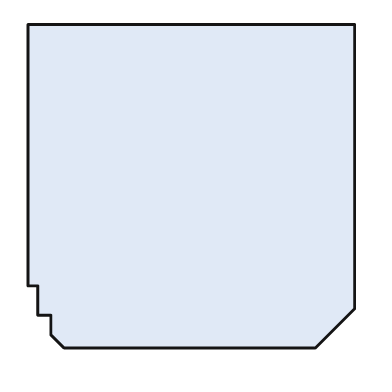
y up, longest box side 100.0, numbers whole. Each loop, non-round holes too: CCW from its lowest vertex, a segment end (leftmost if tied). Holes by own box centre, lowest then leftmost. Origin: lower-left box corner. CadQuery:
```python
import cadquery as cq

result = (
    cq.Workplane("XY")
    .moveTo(11.0, 0.0)
    .lineTo(88.0, 0.0)
    .lineTo(100.0, 12.0)
    .lineTo(100.0, 99.0)
    .lineTo(0.0, 99.0)
    .lineTo(0.0, 19.0)
    .lineTo(3.0, 19.0)
    .lineTo(3.0, 10.0)
    .lineTo(7.0, 10.0)
    .lineTo(7.0, 4.0)
    .close()
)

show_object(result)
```